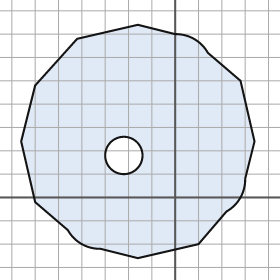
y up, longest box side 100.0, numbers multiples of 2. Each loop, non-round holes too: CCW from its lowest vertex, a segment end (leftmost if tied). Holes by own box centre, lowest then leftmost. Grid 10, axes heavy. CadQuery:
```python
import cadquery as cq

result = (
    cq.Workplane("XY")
    .moveTo(-16.0, -26.0)
    .lineTo(10.0, -20.0)
    .lineTo(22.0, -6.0)
    .threePointArc((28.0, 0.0), (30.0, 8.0))
    .lineTo(34.0, 24.0)
    .lineTo(28.0, 50.0)
    .lineTo(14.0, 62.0)
    .threePointArc((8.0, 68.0), (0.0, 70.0))
    .lineTo(-16.0, 74.0)
    .lineTo(-42.0, 68.0)
    .lineTo(-60.0, 48.0)
    .lineTo(-66.0, 24.0)
    .lineTo(-60.0, -2.0)
    .lineTo(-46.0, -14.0)
    .threePointArc((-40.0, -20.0), (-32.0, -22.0))
    .close()
    .moveTo(-22.0, 18.0)
    .circle(8.0)
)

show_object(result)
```